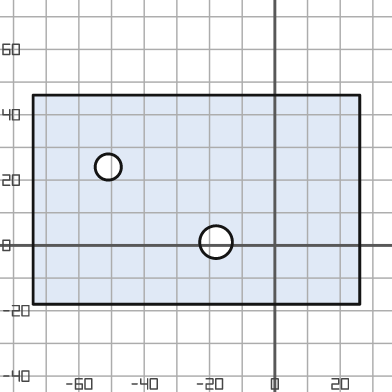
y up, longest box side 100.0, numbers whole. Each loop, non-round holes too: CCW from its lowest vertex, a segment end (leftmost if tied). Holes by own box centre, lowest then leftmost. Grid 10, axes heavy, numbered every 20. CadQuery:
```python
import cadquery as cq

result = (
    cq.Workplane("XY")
    .moveTo(-74.0, -18.0)
    .lineTo(26.0, -18.0)
    .lineTo(26.0, 46.0)
    .lineTo(-74.0, 46.0)
    .close()
    .moveTo(-18.0, 1.0)
    .circle(5.0)
    .moveTo(-51.0, 24.0)
    .circle(4.0)
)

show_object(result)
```